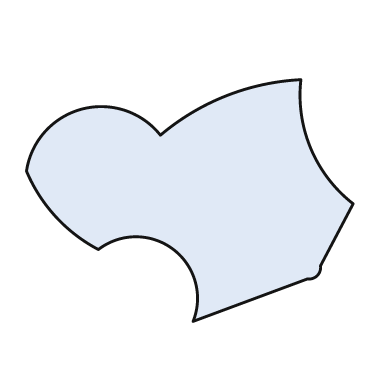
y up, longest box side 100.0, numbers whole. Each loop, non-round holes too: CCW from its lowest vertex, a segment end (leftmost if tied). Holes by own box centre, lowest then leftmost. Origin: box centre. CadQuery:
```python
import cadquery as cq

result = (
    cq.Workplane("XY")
    .moveTo(1.0, -37.0)
    .lineTo(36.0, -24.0)
    .threePointArc((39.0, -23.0), (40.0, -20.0))
    .lineTo(50.0, -1.0)
    .threePointArc((37.0, 16.0), (34.0, 37.0))
    .threePointArc((11.0, 32.0), (-9.0, 20.0))
    .threePointArc((-33.0, 28.0), (-50.0, 9.0))
    .threePointArc((-41.0, -5.0), (-28.0, -15.0))
    .threePointArc((-5.0, -15.0), (1.0, -37.0))
    .close()
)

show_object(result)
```